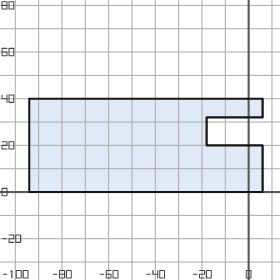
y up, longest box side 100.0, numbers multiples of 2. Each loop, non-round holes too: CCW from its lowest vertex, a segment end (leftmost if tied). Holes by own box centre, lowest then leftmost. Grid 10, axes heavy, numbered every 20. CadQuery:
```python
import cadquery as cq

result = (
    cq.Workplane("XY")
    .moveTo(-94.0, 0.0)
    .lineTo(6.0, 0.0)
    .lineTo(6.0, 20.0)
    .lineTo(-18.0, 20.0)
    .lineTo(-18.0, 32.0)
    .lineTo(6.0, 32.0)
    .lineTo(6.0, 40.0)
    .lineTo(-94.0, 40.0)
    .close()
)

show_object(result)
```